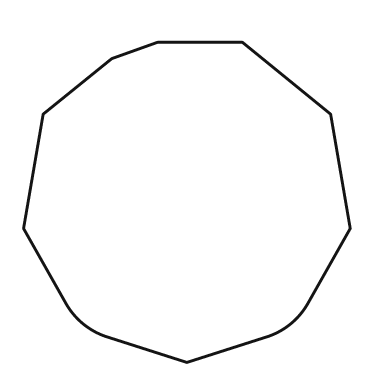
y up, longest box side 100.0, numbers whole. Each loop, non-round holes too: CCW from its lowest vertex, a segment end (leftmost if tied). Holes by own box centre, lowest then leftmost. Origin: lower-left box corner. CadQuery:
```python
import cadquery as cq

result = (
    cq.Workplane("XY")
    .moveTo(50.0, 0.0)
    .lineTo(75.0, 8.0)
    .threePointArc((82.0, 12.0), (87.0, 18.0))
    .lineTo(100.0, 41.0)
    .lineTo(94.0, 76.0)
    .lineTo(67.0, 98.0)
    .lineTo(41.0, 98.0)
    .lineTo(27.0, 93.0)
    .lineTo(6.0, 76.0)
    .lineTo(0.0, 41.0)
    .lineTo(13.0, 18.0)
    .threePointArc((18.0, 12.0), (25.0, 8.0))
    .close()
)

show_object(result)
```